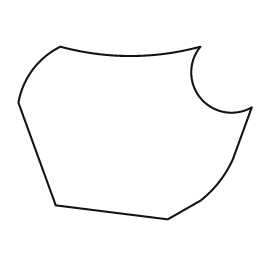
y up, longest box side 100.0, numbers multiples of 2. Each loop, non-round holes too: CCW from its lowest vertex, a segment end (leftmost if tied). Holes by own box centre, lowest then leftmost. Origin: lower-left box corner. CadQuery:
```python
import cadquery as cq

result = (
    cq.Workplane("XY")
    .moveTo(64.0, 0.0)
    .lineTo(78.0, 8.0)
    .threePointArc((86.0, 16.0), (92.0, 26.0))
    .lineTo(100.0, 48.0)
    .threePointArc((78.0, 52.0), (78.0, 74.0))
    .threePointArc((48.0, 70.0), (18.0, 74.0))
    .threePointArc((6.0, 64.0), (0.0, 50.0))
    .lineTo(16.0, 6.0)
    .close()
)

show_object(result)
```